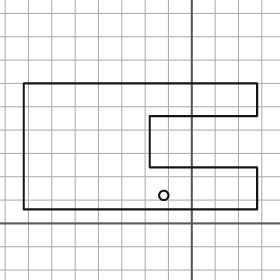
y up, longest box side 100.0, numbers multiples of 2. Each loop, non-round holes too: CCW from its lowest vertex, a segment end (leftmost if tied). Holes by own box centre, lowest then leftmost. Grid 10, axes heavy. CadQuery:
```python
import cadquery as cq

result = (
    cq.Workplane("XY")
    .moveTo(-72.0, 6.0)
    .lineTo(28.0, 6.0)
    .lineTo(28.0, 24.0)
    .lineTo(-18.0, 24.0)
    .lineTo(-18.0, 46.0)
    .lineTo(28.0, 46.0)
    .lineTo(28.0, 60.0)
    .lineTo(-72.0, 60.0)
    .close()
    .moveTo(-12.0, 12.0)
    .circle(2.0)
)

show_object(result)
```